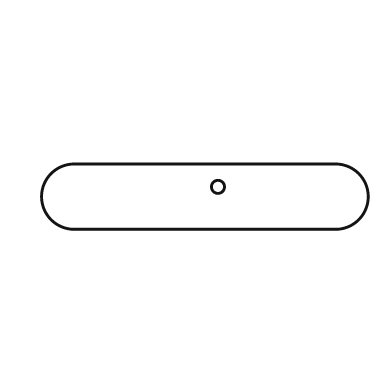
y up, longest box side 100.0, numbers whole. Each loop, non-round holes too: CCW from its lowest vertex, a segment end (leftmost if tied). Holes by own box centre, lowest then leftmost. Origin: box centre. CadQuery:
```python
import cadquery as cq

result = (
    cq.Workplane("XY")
    .moveTo(-40.0, -10.0)
    .lineTo(40.0, -10.0)
    .threePointArc((50.0, 0.0), (40.0, 10.0))
    .lineTo(-40.0, 10.0)
    .threePointArc((-50.0, 0.0), (-40.0, -10.0))
    .close()
    .moveTo(4.0, 3.0)
    .circle(2.0)
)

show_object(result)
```